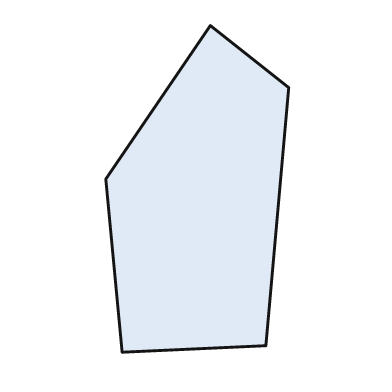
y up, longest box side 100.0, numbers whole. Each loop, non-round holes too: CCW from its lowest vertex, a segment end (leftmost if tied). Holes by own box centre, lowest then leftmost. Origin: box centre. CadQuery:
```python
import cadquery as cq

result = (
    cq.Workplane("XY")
    .moveTo(-23.0, -50.0)
    .lineTo(21.0, -48.0)
    .lineTo(28.0, 31.0)
    .lineTo(4.0, 50.0)
    .lineTo(-28.0, 3.0)
    .close()
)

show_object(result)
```